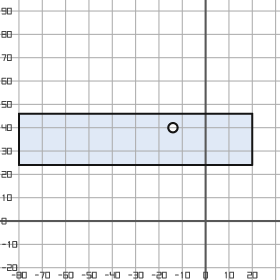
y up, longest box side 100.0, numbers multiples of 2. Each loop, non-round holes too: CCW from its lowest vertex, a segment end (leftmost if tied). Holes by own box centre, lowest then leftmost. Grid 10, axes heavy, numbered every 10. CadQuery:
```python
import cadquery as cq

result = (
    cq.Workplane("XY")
    .moveTo(-80.0, 24.0)
    .lineTo(20.0, 24.0)
    .lineTo(20.0, 46.0)
    .lineTo(-80.0, 46.0)
    .close()
    .moveTo(-14.0, 40.0)
    .circle(2.0)
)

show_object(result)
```